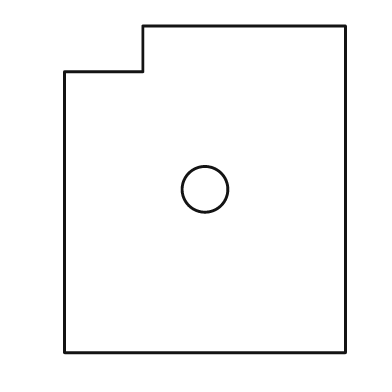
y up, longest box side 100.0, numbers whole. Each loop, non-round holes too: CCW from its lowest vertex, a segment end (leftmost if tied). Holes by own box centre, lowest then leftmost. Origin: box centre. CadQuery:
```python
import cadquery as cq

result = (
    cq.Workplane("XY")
    .moveTo(-43.0, -50.0)
    .lineTo(43.0, -50.0)
    .lineTo(43.0, 50.0)
    .lineTo(-19.0, 50.0)
    .lineTo(-19.0, 36.0)
    .lineTo(-43.0, 36.0)
    .close()
    .moveTo(0.0, 0.0)
    .circle(7.0)
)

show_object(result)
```